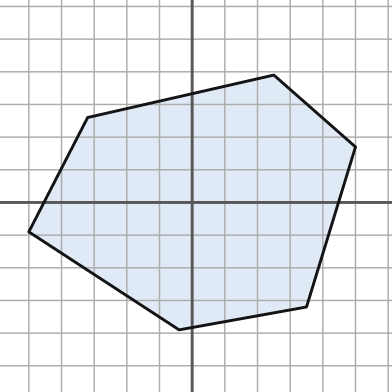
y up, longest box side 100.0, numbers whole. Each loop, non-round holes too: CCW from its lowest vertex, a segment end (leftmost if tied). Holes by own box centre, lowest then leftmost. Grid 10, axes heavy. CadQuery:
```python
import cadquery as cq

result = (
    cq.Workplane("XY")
    .moveTo(-4.0, -39.0)
    .lineTo(35.0, -32.0)
    .lineTo(50.0, 17.0)
    .lineTo(25.0, 39.0)
    .lineTo(-32.0, 26.0)
    .lineTo(-50.0, -9.0)
    .close()
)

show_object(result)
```